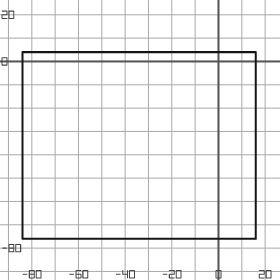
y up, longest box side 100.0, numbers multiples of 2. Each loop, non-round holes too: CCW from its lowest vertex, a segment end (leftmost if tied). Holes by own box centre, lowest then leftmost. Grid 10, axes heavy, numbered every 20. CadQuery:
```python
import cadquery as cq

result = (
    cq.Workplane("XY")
    .moveTo(-84.0, -76.0)
    .lineTo(16.0, -76.0)
    .lineTo(16.0, 4.0)
    .lineTo(-84.0, 4.0)
    .close()
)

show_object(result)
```